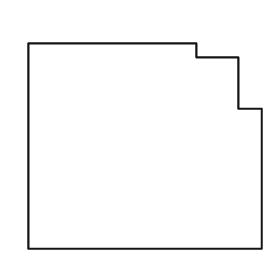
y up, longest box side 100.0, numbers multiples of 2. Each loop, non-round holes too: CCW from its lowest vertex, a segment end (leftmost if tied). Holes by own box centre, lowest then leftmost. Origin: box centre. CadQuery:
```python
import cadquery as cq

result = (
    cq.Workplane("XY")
    .moveTo(-50.0, -44.0)
    .lineTo(50.0, -44.0)
    .lineTo(50.0, 16.0)
    .lineTo(40.0, 16.0)
    .lineTo(40.0, 38.0)
    .lineTo(22.0, 38.0)
    .lineTo(22.0, 44.0)
    .lineTo(-50.0, 44.0)
    .close()
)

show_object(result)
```